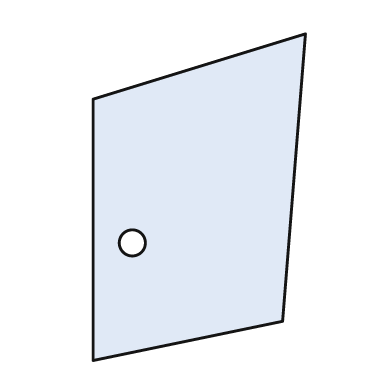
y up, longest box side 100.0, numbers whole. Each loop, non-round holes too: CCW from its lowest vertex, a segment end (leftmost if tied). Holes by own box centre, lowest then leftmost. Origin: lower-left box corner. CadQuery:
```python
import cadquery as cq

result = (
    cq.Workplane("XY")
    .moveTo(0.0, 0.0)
    .lineTo(58.0, 12.0)
    .lineTo(65.0, 100.0)
    .lineTo(0.0, 80.0)
    .close()
    .moveTo(12.0, 36.0)
    .circle(4.0)
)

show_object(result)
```